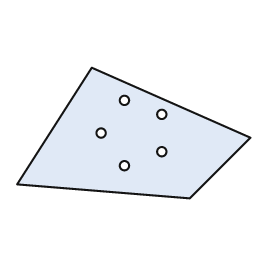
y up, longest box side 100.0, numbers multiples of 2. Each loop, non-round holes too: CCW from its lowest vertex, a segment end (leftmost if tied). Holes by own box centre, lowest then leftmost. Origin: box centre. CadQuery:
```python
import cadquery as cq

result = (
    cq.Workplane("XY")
    .moveTo(24.0, -28.0)
    .lineTo(50.0, -2.0)
    .lineTo(-18.0, 28.0)
    .lineTo(-50.0, -22.0)
    .close()
    .moveTo(-4.0, -14.0)
    .circle(2.0)
    .moveTo(12.0, -8.0)
    .circle(2.0)
    .moveTo(-14.0, 0.0)
    .circle(2.0)
    .moveTo(12.0, 8.0)
    .circle(2.0)
    .moveTo(-4.0, 14.0)
    .circle(2.0)
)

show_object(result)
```